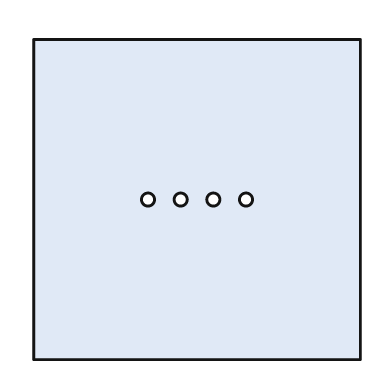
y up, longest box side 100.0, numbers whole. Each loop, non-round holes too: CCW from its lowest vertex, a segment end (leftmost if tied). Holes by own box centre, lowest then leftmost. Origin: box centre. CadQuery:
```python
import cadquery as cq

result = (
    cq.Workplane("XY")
    .moveTo(-50.0, -49.0)
    .lineTo(50.0, -49.0)
    .lineTo(50.0, 49.0)
    .lineTo(-50.0, 49.0)
    .close()
    .moveTo(-15.0, 0.0)
    .circle(2.0)
    .moveTo(-5.0, 0.0)
    .circle(2.0)
    .moveTo(5.0, 0.0)
    .circle(2.0)
    .moveTo(15.0, 0.0)
    .circle(2.0)
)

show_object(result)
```